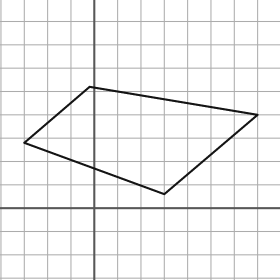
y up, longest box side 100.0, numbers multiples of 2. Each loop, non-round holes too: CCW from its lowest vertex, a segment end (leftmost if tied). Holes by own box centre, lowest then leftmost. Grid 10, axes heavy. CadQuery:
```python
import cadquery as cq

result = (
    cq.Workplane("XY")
    .moveTo(30.0, 6.0)
    .lineTo(70.0, 40.0)
    .lineTo(-2.0, 52.0)
    .lineTo(-30.0, 28.0)
    .close()
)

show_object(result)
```